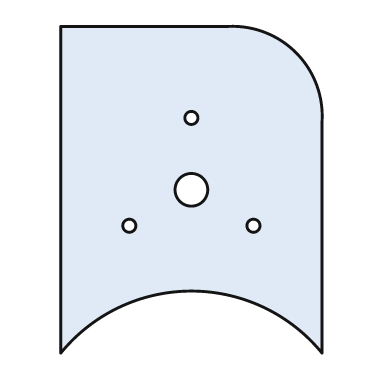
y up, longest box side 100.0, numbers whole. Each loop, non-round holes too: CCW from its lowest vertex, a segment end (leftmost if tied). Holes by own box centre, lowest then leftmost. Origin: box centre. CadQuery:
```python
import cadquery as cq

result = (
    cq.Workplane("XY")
    .moveTo(-40.0, -50.0)
    .threePointArc((0.0, -31.0), (40.0, -50.0))
    .lineTo(40.0, 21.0)
    .threePointArc((32.0, 42.0), (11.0, 50.0))
    .lineTo(-40.0, 50.0)
    .close()
    .moveTo(-19.0, -11.0)
    .circle(2.0)
    .moveTo(19.0, -11.0)
    .circle(2.0)
    .moveTo(0.0, 0.0)
    .circle(5.0)
    .moveTo(0.0, 22.0)
    .circle(2.0)
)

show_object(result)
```